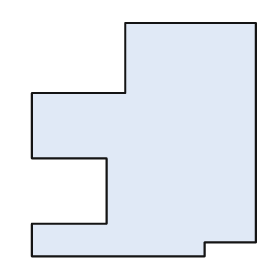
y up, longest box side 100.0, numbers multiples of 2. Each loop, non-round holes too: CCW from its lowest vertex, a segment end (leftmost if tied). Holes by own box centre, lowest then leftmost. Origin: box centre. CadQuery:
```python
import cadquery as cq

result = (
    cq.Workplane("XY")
    .moveTo(-48.0, -50.0)
    .lineTo(26.0, -50.0)
    .lineTo(26.0, -44.0)
    .lineTo(48.0, -44.0)
    .lineTo(48.0, 50.0)
    .lineTo(-8.0, 50.0)
    .lineTo(-8.0, 20.0)
    .lineTo(-48.0, 20.0)
    .lineTo(-48.0, -8.0)
    .lineTo(-16.0, -8.0)
    .lineTo(-16.0, -36.0)
    .lineTo(-48.0, -36.0)
    .close()
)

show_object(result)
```